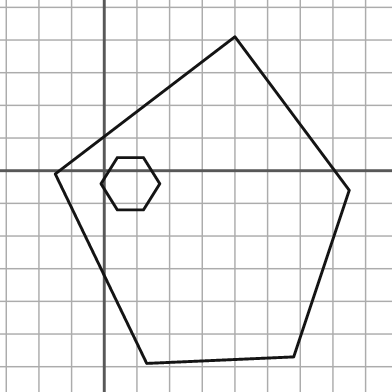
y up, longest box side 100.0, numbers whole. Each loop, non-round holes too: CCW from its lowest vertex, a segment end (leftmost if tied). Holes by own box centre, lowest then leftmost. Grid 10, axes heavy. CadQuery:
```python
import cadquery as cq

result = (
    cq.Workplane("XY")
    .moveTo(13.0, -59.0)
    .lineTo(58.0, -57.0)
    .lineTo(75.0, -6.0)
    .lineTo(40.0, 41.0)
    .lineTo(-15.0, -1.0)
    .close()
    .moveTo(4.0, -12.0)
    .lineTo(12.0, -12.0)
    .lineTo(17.0, -4.0)
    .lineTo(12.0, 4.0)
    .lineTo(4.0, 4.0)
    .lineTo(-1.0, -4.0)
    .close()
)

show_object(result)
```